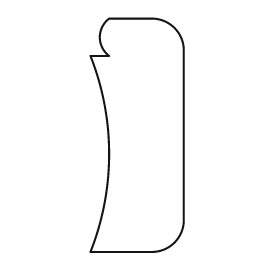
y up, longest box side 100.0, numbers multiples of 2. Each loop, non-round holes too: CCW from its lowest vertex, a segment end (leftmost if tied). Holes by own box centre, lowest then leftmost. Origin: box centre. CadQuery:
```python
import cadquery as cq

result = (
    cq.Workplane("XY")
    .moveTo(-20.0, -50.0)
    .lineTo(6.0, -50.0)
    .threePointArc((16.0, -46.0), (20.0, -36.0))
    .lineTo(20.0, 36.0)
    .threePointArc((16.0, 46.0), (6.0, 50.0))
    .lineTo(-12.0, 50.0)
    .threePointArc((-16.0, 42.0), (-12.0, 34.0))
    .lineTo(-20.0, 34.0)
    .threePointArc((-12.0, -8.0), (-20.0, -50.0))
    .close()
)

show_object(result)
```